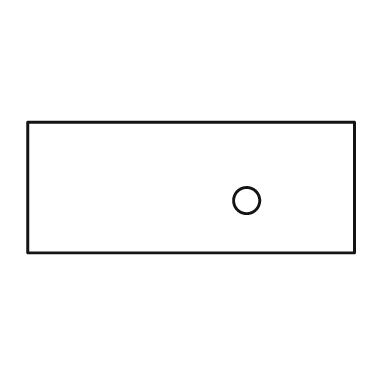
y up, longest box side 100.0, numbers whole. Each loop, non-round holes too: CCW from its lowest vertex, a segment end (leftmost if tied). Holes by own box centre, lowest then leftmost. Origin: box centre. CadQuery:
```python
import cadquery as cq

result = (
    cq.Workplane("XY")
    .moveTo(-50.0, -20.0)
    .lineTo(50.0, -20.0)
    .lineTo(50.0, 20.0)
    .lineTo(-50.0, 20.0)
    .close()
    .moveTo(17.0, -4.0)
    .circle(4.0)
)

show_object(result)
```